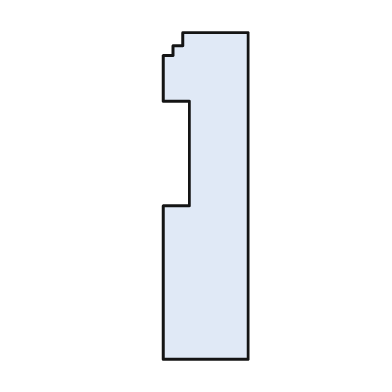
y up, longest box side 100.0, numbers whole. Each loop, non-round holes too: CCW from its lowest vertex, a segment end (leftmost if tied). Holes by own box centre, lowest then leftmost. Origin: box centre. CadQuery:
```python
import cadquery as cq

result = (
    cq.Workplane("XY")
    .moveTo(-13.0, -50.0)
    .lineTo(13.0, -50.0)
    .lineTo(13.0, 50.0)
    .lineTo(-7.0, 50.0)
    .lineTo(-7.0, 46.0)
    .lineTo(-10.0, 46.0)
    .lineTo(-10.0, 43.0)
    .lineTo(-13.0, 43.0)
    .lineTo(-13.0, 29.0)
    .lineTo(-5.0, 29.0)
    .lineTo(-5.0, -3.0)
    .lineTo(-13.0, -3.0)
    .close()
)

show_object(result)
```